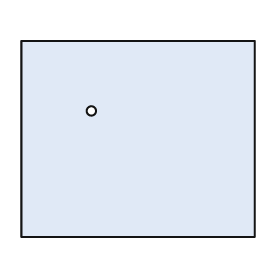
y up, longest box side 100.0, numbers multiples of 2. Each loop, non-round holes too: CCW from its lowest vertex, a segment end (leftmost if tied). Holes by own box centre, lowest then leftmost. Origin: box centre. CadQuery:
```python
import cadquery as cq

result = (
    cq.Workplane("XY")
    .moveTo(-50.0, -42.0)
    .lineTo(50.0, -42.0)
    .lineTo(50.0, 42.0)
    .lineTo(-50.0, 42.0)
    .close()
    .moveTo(-20.0, 12.0)
    .circle(2.0)
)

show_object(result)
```